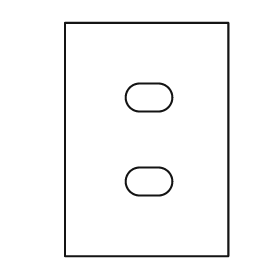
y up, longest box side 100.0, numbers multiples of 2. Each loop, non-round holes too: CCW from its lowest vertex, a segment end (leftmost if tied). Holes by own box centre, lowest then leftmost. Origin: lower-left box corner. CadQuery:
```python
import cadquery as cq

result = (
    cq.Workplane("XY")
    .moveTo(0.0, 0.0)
    .lineTo(70.0, 0.0)
    .lineTo(70.0, 100.0)
    .lineTo(0.0, 100.0)
    .close()
    .moveTo(32.0, 26.0)
    .lineTo(40.0, 26.0)
    .threePointArc((46.0, 32.0), (40.0, 38.0))
    .lineTo(32.0, 38.0)
    .threePointArc((26.0, 32.0), (32.0, 26.0))
    .close()
    .moveTo(32.0, 62.0)
    .lineTo(40.0, 62.0)
    .threePointArc((46.0, 68.0), (40.0, 74.0))
    .lineTo(32.0, 74.0)
    .threePointArc((26.0, 68.0), (32.0, 62.0))
    .close()
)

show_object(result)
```